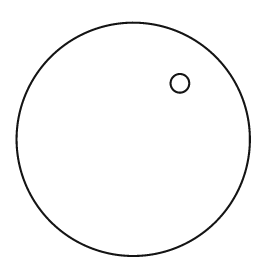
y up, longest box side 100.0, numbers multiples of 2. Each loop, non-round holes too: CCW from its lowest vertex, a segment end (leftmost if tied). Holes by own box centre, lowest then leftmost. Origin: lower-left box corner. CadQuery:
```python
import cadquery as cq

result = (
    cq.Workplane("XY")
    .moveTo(50.0, 50.0)
    .circle(50.0)
    .moveTo(70.0, 74.0)
    .circle(4.0)
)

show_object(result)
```